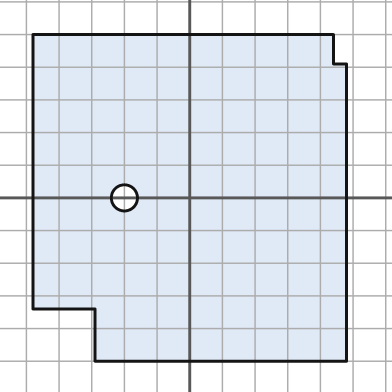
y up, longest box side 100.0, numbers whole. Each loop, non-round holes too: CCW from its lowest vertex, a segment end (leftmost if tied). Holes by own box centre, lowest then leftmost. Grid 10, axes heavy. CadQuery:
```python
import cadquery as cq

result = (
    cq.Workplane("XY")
    .moveTo(-29.0, -50.0)
    .lineTo(48.0, -50.0)
    .lineTo(48.0, 41.0)
    .lineTo(44.0, 41.0)
    .lineTo(44.0, 50.0)
    .lineTo(-48.0, 50.0)
    .lineTo(-48.0, -34.0)
    .lineTo(-29.0, -34.0)
    .close()
    .moveTo(-20.0, 0.0)
    .circle(4.0)
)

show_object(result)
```